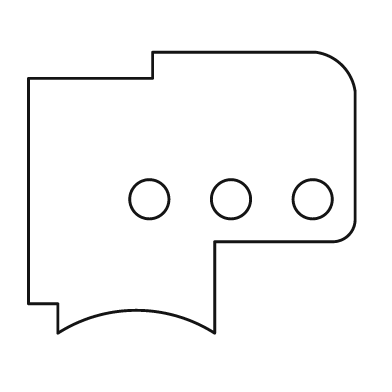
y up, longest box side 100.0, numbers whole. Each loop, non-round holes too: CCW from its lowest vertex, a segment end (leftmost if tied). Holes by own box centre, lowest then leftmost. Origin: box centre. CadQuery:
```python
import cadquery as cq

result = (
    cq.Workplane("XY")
    .moveTo(-41.0, -43.0)
    .threePointArc((-17.0, -36.0), (7.0, -43.0))
    .lineTo(7.0, -15.0)
    .lineTo(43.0, -15.0)
    .threePointArc((48.0, -13.0), (50.0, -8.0))
    .lineTo(50.0, 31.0)
    .threePointArc((46.0, 39.0), (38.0, 43.0))
    .lineTo(-12.0, 43.0)
    .lineTo(-12.0, 35.0)
    .lineTo(-50.0, 35.0)
    .lineTo(-50.0, -34.0)
    .lineTo(-41.0, -34.0)
    .close()
    .moveTo(-13.0, -2.0)
    .circle(6.0)
    .moveTo(12.0, -2.0)
    .circle(6.0)
    .moveTo(37.0, -2.0)
    .circle(6.0)
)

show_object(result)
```